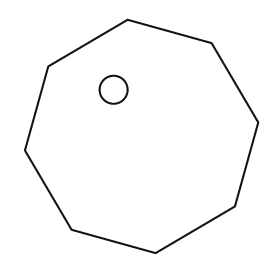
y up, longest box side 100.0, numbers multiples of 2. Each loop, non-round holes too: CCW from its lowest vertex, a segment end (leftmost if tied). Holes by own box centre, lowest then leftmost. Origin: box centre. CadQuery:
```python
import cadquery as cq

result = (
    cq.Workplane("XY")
    .moveTo(6.0, -50.0)
    .lineTo(40.0, -30.0)
    .lineTo(50.0, 6.0)
    .lineTo(30.0, 40.0)
    .lineTo(-6.0, 50.0)
    .lineTo(-40.0, 30.0)
    .lineTo(-50.0, -6.0)
    .lineTo(-30.0, -40.0)
    .close()
    .moveTo(-12.0, 20.0)
    .circle(6.0)
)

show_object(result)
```